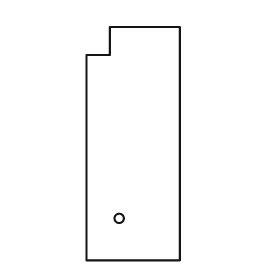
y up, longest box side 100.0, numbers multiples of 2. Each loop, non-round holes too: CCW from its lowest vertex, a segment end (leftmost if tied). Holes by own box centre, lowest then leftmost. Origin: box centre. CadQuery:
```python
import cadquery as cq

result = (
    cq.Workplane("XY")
    .moveTo(-20.0, -50.0)
    .lineTo(20.0, -50.0)
    .lineTo(20.0, 50.0)
    .lineTo(-10.0, 50.0)
    .lineTo(-10.0, 38.0)
    .lineTo(-20.0, 38.0)
    .close()
    .moveTo(-6.0, -32.0)
    .circle(2.0)
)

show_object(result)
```